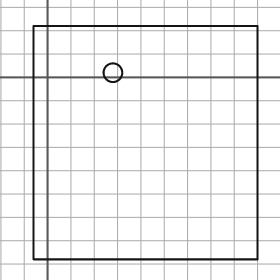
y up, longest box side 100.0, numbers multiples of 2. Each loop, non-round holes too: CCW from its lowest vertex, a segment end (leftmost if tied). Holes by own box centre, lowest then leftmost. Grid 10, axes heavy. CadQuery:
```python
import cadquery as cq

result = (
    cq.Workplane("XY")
    .moveTo(-6.0, -78.0)
    .lineTo(90.0, -78.0)
    .lineTo(90.0, 22.0)
    .lineTo(-6.0, 22.0)
    .close()
    .moveTo(28.0, 2.0)
    .circle(4.0)
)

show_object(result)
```